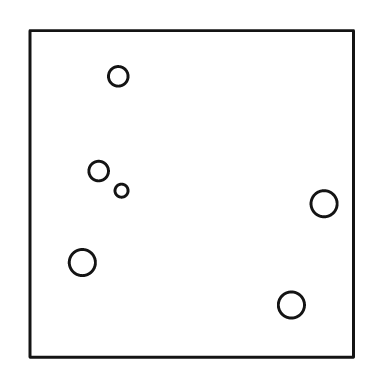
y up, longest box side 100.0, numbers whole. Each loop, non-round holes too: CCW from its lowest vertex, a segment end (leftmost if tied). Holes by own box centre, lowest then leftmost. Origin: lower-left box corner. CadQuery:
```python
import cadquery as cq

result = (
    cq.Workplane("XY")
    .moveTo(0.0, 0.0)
    .lineTo(99.0, 0.0)
    .lineTo(99.0, 100.0)
    .lineTo(0.0, 100.0)
    .close()
    .moveTo(80.0, 16.0)
    .circle(4.0)
    .moveTo(16.0, 29.0)
    .circle(4.0)
    .moveTo(90.0, 47.0)
    .circle(4.0)
    .moveTo(28.0, 51.0)
    .circle(2.0)
    .moveTo(21.0, 57.0)
    .circle(3.0)
    .moveTo(27.0, 86.0)
    .circle(3.0)
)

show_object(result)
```